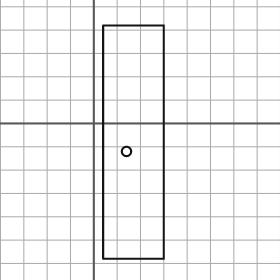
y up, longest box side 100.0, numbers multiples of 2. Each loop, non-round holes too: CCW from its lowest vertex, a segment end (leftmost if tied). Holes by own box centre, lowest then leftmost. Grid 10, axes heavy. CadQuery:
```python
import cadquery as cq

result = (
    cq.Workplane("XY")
    .moveTo(4.0, -58.0)
    .lineTo(30.0, -58.0)
    .lineTo(30.0, 42.0)
    .lineTo(4.0, 42.0)
    .close()
    .moveTo(14.0, -12.0)
    .circle(2.0)
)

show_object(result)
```